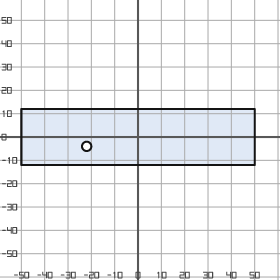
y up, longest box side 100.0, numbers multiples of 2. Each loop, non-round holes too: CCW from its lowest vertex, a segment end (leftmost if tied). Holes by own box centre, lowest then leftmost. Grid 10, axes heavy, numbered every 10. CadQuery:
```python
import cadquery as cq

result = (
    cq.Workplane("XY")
    .moveTo(-50.0, -12.0)
    .lineTo(50.0, -12.0)
    .lineTo(50.0, 12.0)
    .lineTo(-50.0, 12.0)
    .close()
    .moveTo(-22.0, -4.0)
    .circle(2.0)
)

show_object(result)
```